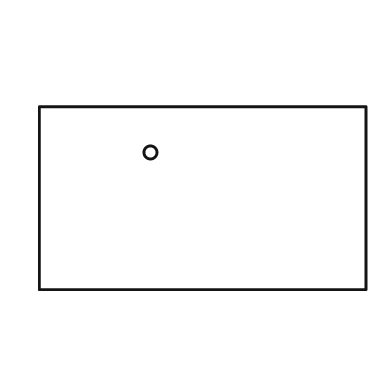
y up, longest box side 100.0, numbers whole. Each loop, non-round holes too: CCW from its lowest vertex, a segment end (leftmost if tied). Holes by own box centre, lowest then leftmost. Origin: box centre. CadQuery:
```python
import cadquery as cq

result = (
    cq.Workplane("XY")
    .moveTo(-50.0, -28.0)
    .lineTo(50.0, -28.0)
    .lineTo(50.0, 28.0)
    .lineTo(-50.0, 28.0)
    .close()
    .moveTo(-16.0, 14.0)
    .circle(2.0)
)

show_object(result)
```